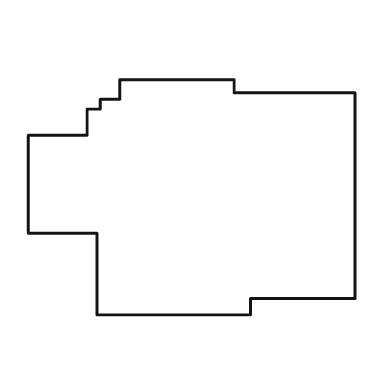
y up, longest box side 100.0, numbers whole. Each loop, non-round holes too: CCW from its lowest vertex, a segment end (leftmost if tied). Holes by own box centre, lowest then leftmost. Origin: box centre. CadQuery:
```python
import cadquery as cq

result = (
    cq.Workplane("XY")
    .moveTo(-29.0, -36.0)
    .lineTo(18.0, -36.0)
    .lineTo(18.0, -31.0)
    .lineTo(50.0, -31.0)
    .lineTo(50.0, 32.0)
    .lineTo(13.0, 32.0)
    .lineTo(13.0, 36.0)
    .lineTo(-22.0, 36.0)
    .lineTo(-22.0, 30.0)
    .lineTo(-28.0, 30.0)
    .lineTo(-28.0, 27.0)
    .lineTo(-32.0, 27.0)
    .lineTo(-32.0, 19.0)
    .lineTo(-50.0, 19.0)
    .lineTo(-50.0, -11.0)
    .lineTo(-29.0, -11.0)
    .close()
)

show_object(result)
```